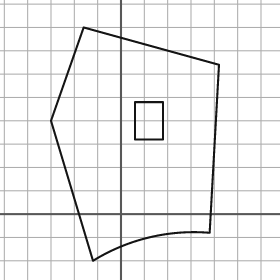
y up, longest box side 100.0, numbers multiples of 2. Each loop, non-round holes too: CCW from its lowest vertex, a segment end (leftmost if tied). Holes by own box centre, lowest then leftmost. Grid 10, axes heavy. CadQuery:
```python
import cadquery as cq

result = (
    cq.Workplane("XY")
    .moveTo(-12.0, -20.0)
    .threePointArc((12.0, -10.0), (38.0, -8.0))
    .lineTo(42.0, 64.0)
    .lineTo(-16.0, 80.0)
    .lineTo(-30.0, 40.0)
    .close()
    .moveTo(6.0, 32.0)
    .lineTo(18.0, 32.0)
    .lineTo(18.0, 48.0)
    .lineTo(6.0, 48.0)
    .close()
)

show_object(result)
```